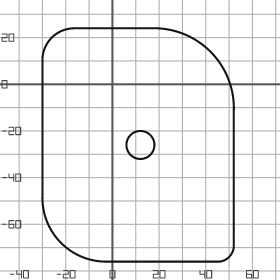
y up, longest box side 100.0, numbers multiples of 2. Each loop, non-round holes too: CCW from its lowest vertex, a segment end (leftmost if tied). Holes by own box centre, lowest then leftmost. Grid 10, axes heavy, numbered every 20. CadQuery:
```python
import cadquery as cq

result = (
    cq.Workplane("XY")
    .moveTo(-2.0, -76.0)
    .lineTo(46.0, -76.0)
    .threePointArc((50.0, -74.0), (52.0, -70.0))
    .lineTo(52.0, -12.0)
    .threePointArc((42.0, 14.0), (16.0, 24.0))
    .lineTo(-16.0, 24.0)
    .threePointArc((-26.0, 20.0), (-30.0, 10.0))
    .lineTo(-30.0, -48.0)
    .threePointArc((-22.0, -68.0), (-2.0, -76.0))
    .close()
    .moveTo(12.0, -26.0)
    .circle(6.0)
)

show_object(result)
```